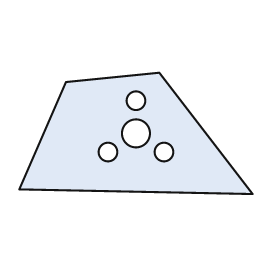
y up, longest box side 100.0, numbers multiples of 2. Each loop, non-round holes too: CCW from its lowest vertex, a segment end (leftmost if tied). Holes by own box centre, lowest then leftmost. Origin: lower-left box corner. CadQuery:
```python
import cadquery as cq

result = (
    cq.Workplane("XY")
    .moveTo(100.0, 0.0)
    .lineTo(60.0, 52.0)
    .lineTo(20.0, 48.0)
    .lineTo(0.0, 2.0)
    .close()
    .moveTo(38.0, 18.0)
    .circle(4.0)
    .moveTo(62.0, 18.0)
    .circle(4.0)
    .moveTo(50.0, 26.0)
    .circle(6.0)
    .moveTo(50.0, 40.0)
    .circle(4.0)
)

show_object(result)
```